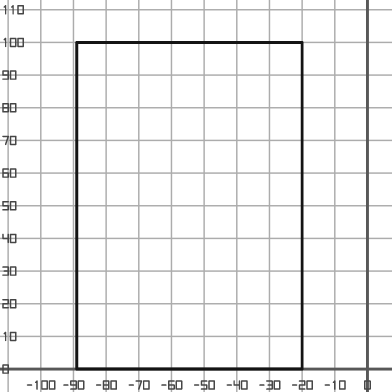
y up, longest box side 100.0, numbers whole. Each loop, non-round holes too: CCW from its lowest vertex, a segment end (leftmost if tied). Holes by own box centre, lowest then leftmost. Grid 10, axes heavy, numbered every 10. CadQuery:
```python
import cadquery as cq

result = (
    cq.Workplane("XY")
    .moveTo(-89.0, 0.0)
    .lineTo(-20.0, 0.0)
    .lineTo(-20.0, 100.0)
    .lineTo(-89.0, 100.0)
    .close()
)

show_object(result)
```